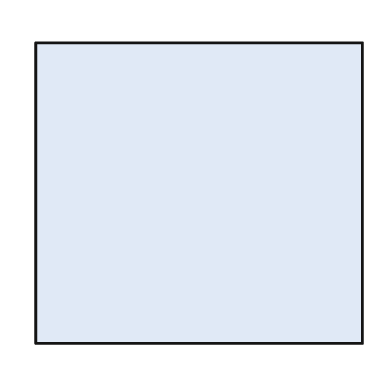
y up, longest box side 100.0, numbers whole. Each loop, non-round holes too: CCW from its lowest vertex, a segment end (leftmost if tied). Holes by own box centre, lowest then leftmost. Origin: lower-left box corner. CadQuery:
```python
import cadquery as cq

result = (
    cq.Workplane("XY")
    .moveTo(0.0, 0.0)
    .lineTo(100.0, 0.0)
    .lineTo(100.0, 92.0)
    .lineTo(0.0, 92.0)
    .close()
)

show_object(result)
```